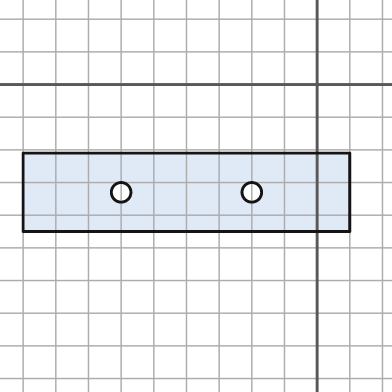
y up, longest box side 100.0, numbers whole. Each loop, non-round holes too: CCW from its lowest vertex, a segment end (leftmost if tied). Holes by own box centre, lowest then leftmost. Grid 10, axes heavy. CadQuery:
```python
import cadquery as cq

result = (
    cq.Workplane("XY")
    .moveTo(-90.0, -45.0)
    .lineTo(10.0, -45.0)
    .lineTo(10.0, -21.0)
    .lineTo(-90.0, -21.0)
    .close()
    .moveTo(-60.0, -33.0)
    .circle(3.0)
    .moveTo(-20.0, -33.0)
    .circle(3.0)
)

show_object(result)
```